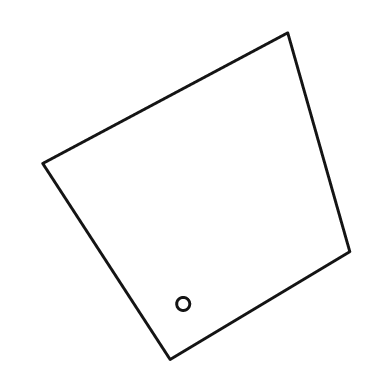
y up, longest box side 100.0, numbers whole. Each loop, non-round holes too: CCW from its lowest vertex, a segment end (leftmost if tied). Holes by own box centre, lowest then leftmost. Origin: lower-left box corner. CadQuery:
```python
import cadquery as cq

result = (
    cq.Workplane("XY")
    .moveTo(39.0, 0.0)
    .lineTo(94.0, 33.0)
    .lineTo(75.0, 100.0)
    .lineTo(0.0, 60.0)
    .close()
    .moveTo(43.0, 17.0)
    .circle(2.0)
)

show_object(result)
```